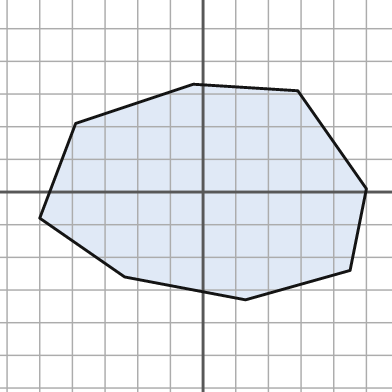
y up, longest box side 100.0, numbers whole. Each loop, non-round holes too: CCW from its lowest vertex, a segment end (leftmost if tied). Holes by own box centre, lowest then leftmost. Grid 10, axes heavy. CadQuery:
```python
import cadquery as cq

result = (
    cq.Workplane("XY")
    .moveTo(13.0, -33.0)
    .lineTo(45.0, -24.0)
    .lineTo(50.0, 1.0)
    .lineTo(29.0, 31.0)
    .lineTo(-3.0, 33.0)
    .lineTo(-39.0, 21.0)
    .lineTo(-50.0, -8.0)
    .lineTo(-24.0, -26.0)
    .close()
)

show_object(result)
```